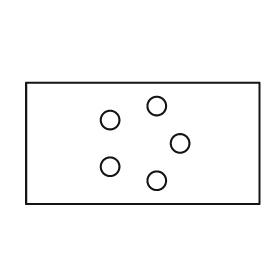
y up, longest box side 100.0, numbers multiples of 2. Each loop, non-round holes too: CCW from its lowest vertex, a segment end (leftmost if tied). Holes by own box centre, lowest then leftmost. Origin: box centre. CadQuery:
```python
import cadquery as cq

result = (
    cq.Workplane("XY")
    .moveTo(-50.0, -26.0)
    .lineTo(50.0, -26.0)
    .lineTo(50.0, 26.0)
    .lineTo(-50.0, 26.0)
    .close()
    .moveTo(6.0, -16.0)
    .circle(4.0)
    .moveTo(-14.0, -10.0)
    .circle(4.0)
    .moveTo(16.0, 0.0)
    .circle(4.0)
    .moveTo(-14.0, 10.0)
    .circle(4.0)
    .moveTo(6.0, 16.0)
    .circle(4.0)
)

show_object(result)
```